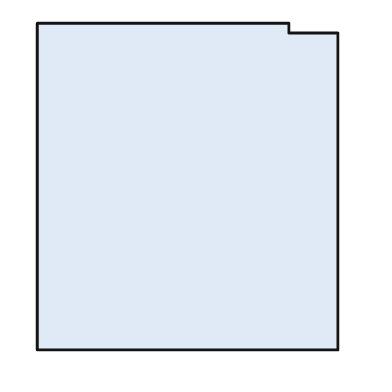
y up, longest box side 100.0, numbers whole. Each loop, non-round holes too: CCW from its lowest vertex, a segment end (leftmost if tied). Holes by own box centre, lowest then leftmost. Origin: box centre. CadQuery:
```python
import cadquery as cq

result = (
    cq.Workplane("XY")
    .moveTo(-46.0, -50.0)
    .lineTo(46.0, -50.0)
    .lineTo(46.0, 47.0)
    .lineTo(31.0, 47.0)
    .lineTo(31.0, 50.0)
    .lineTo(-46.0, 50.0)
    .close()
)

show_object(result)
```